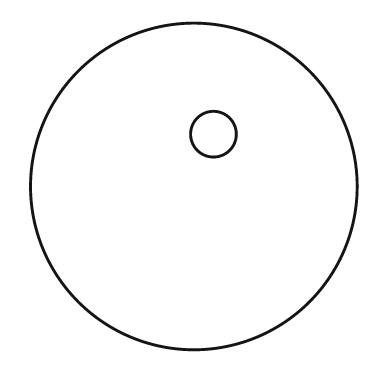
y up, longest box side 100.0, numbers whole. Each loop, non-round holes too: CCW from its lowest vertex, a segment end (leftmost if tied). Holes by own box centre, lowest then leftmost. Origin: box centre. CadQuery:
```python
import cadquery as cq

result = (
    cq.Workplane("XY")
    .moveTo(0.0, 0.0)
    .circle(50.0)
    .moveTo(6.0, 16.0)
    .circle(7.0)
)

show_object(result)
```